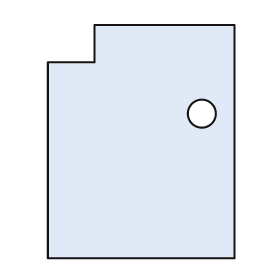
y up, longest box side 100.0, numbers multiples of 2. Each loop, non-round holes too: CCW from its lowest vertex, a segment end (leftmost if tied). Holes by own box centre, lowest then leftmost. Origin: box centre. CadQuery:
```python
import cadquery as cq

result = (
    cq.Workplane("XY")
    .moveTo(-40.0, -50.0)
    .lineTo(40.0, -50.0)
    .lineTo(40.0, 50.0)
    .lineTo(-20.0, 50.0)
    .lineTo(-20.0, 34.0)
    .lineTo(-40.0, 34.0)
    .close()
    .moveTo(26.0, 12.0)
    .circle(6.0)
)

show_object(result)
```